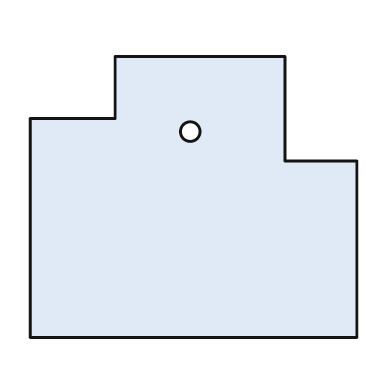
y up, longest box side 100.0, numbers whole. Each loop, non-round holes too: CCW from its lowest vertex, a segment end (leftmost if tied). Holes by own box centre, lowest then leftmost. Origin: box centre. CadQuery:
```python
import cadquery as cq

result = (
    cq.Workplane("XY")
    .moveTo(-50.0, -43.0)
    .lineTo(50.0, -43.0)
    .lineTo(50.0, 11.0)
    .lineTo(28.0, 11.0)
    .lineTo(28.0, 43.0)
    .lineTo(-24.0, 43.0)
    .lineTo(-24.0, 24.0)
    .lineTo(-50.0, 24.0)
    .close()
    .moveTo(-1.0, 20.0)
    .circle(3.0)
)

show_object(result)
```